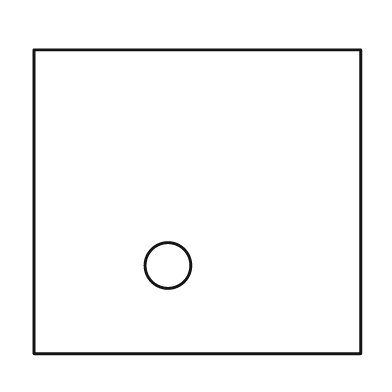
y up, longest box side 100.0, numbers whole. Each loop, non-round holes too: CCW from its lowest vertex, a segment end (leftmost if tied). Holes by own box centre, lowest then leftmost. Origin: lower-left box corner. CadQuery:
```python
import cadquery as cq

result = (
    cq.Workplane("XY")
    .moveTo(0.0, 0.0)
    .lineTo(100.0, 0.0)
    .lineTo(100.0, 93.0)
    .lineTo(0.0, 93.0)
    .close()
    .moveTo(41.0, 27.0)
    .circle(7.0)
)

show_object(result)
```